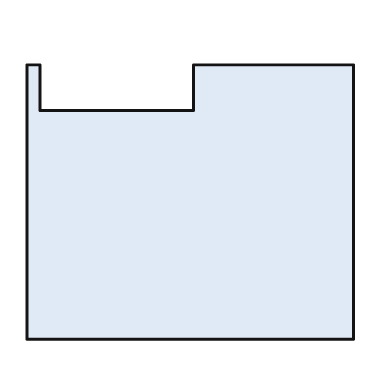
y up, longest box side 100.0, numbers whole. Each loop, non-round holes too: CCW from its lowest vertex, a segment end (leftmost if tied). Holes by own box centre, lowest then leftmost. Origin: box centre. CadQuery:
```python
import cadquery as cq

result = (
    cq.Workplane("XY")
    .moveTo(-50.0, -42.0)
    .lineTo(50.0, -42.0)
    .lineTo(50.0, 42.0)
    .lineTo(1.0, 42.0)
    .lineTo(1.0, 28.0)
    .lineTo(-46.0, 28.0)
    .lineTo(-46.0, 42.0)
    .lineTo(-50.0, 42.0)
    .close()
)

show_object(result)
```